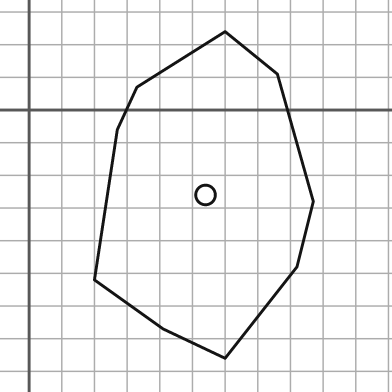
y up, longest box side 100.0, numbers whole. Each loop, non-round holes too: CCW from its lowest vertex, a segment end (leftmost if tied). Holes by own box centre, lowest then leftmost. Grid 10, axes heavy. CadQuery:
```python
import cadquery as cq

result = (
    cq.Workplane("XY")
    .moveTo(60.0, -76.0)
    .lineTo(82.0, -48.0)
    .lineTo(87.0, -28.0)
    .lineTo(76.0, 11.0)
    .lineTo(60.0, 24.0)
    .lineTo(33.0, 7.0)
    .lineTo(27.0, -6.0)
    .lineTo(20.0, -52.0)
    .lineTo(41.0, -67.0)
    .close()
    .moveTo(54.0, -26.0)
    .circle(3.0)
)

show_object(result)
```